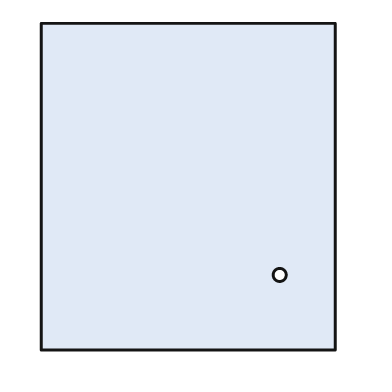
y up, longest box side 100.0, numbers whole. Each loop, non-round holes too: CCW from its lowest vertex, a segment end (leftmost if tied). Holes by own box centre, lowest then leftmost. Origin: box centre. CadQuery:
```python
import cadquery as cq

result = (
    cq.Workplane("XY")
    .moveTo(-45.0, -50.0)
    .lineTo(45.0, -50.0)
    .lineTo(45.0, 50.0)
    .lineTo(-45.0, 50.0)
    .close()
    .moveTo(28.0, -27.0)
    .circle(2.0)
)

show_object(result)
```